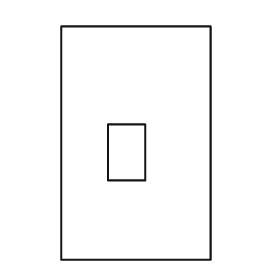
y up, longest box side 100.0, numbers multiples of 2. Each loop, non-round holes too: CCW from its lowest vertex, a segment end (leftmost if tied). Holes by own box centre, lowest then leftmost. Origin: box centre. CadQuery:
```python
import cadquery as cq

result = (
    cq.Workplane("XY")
    .moveTo(-32.0, -50.0)
    .lineTo(32.0, -50.0)
    .lineTo(32.0, 50.0)
    .lineTo(-32.0, 50.0)
    .close()
    .moveTo(-12.0, -16.0)
    .lineTo(4.0, -16.0)
    .lineTo(4.0, 8.0)
    .lineTo(-12.0, 8.0)
    .close()
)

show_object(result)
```